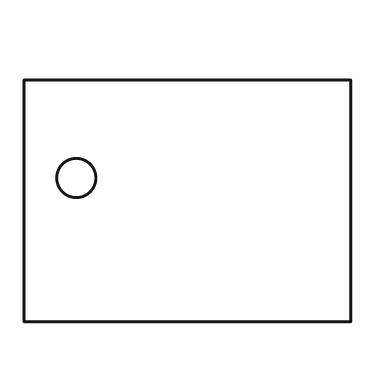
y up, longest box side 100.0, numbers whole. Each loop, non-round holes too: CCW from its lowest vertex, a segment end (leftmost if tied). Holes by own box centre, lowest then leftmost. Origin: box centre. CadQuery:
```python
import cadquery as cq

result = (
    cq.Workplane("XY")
    .moveTo(-50.0, -37.0)
    .lineTo(50.0, -37.0)
    .lineTo(50.0, 37.0)
    .lineTo(-50.0, 37.0)
    .close()
    .moveTo(-34.0, 7.0)
    .circle(6.0)
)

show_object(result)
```